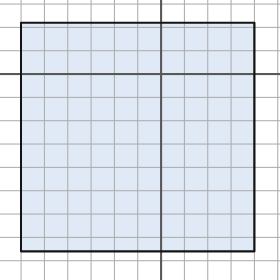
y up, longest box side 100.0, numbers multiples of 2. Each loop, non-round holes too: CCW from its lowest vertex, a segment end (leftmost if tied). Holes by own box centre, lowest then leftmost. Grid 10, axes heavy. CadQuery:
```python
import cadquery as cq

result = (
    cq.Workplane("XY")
    .moveTo(-60.0, -76.0)
    .lineTo(40.0, -76.0)
    .lineTo(40.0, 22.0)
    .lineTo(-60.0, 22.0)
    .close()
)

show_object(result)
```